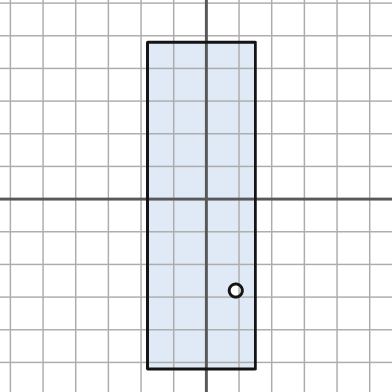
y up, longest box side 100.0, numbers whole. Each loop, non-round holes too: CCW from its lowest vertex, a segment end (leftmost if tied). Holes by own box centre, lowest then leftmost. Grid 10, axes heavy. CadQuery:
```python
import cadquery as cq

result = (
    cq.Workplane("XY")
    .moveTo(-18.0, -52.0)
    .lineTo(15.0, -52.0)
    .lineTo(15.0, 48.0)
    .lineTo(-18.0, 48.0)
    .close()
    .moveTo(9.0, -28.0)
    .circle(2.0)
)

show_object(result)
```